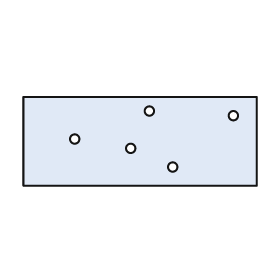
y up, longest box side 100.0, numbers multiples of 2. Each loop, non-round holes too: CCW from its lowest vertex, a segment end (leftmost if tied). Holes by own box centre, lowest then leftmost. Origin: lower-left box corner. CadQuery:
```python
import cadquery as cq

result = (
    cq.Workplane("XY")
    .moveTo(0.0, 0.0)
    .lineTo(100.0, 0.0)
    .lineTo(100.0, 38.0)
    .lineTo(0.0, 38.0)
    .close()
    .moveTo(64.0, 8.0)
    .circle(2.0)
    .moveTo(46.0, 16.0)
    .circle(2.0)
    .moveTo(22.0, 20.0)
    .circle(2.0)
    .moveTo(90.0, 30.0)
    .circle(2.0)
    .moveTo(54.0, 32.0)
    .circle(2.0)
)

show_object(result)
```